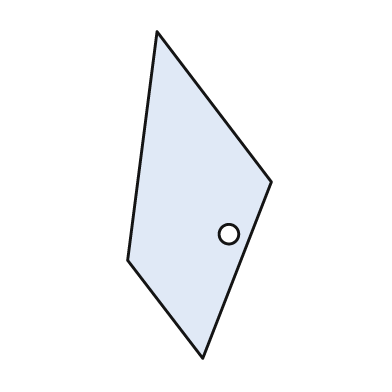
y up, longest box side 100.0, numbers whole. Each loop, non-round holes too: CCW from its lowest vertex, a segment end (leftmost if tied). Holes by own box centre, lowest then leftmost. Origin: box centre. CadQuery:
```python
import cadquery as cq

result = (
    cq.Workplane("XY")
    .moveTo(1.0, -50.0)
    .lineTo(22.0, 4.0)
    .lineTo(-13.0, 50.0)
    .lineTo(-22.0, -20.0)
    .close()
    .moveTo(9.0, -12.0)
    .circle(3.0)
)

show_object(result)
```